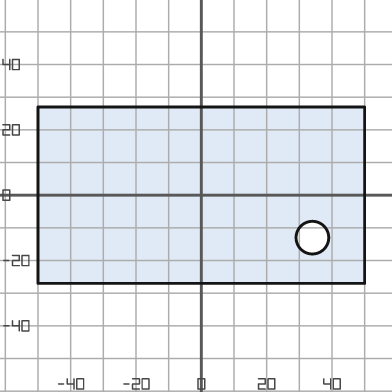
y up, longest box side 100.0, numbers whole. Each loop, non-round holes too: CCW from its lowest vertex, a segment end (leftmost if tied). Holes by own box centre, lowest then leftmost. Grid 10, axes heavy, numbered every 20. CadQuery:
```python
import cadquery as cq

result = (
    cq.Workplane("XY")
    .moveTo(-50.0, -27.0)
    .lineTo(50.0, -27.0)
    .lineTo(50.0, 27.0)
    .lineTo(-50.0, 27.0)
    .close()
    .moveTo(34.0, -13.0)
    .circle(5.0)
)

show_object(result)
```